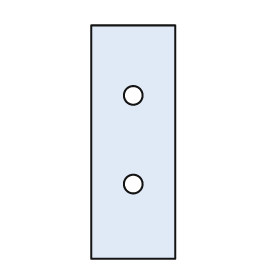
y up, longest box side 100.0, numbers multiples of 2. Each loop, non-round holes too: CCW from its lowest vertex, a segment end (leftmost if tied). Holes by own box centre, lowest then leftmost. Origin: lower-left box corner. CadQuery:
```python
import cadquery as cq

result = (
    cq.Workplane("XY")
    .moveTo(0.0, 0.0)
    .lineTo(36.0, 0.0)
    .lineTo(36.0, 100.0)
    .lineTo(0.0, 100.0)
    .close()
    .moveTo(18.0, 32.0)
    .circle(4.0)
    .moveTo(18.0, 70.0)
    .circle(4.0)
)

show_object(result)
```